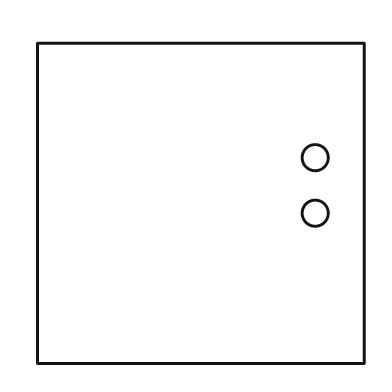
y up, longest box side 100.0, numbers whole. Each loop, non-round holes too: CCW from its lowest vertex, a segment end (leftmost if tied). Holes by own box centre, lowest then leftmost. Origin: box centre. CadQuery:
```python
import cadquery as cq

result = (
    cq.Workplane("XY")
    .moveTo(-50.0, -49.0)
    .lineTo(50.0, -49.0)
    .lineTo(50.0, 49.0)
    .lineTo(-50.0, 49.0)
    .close()
    .moveTo(35.0, -3.0)
    .circle(4.0)
    .moveTo(35.0, 14.0)
    .circle(4.0)
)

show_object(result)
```